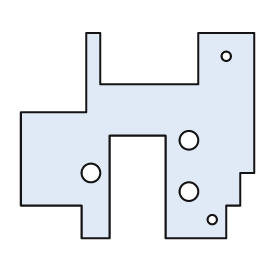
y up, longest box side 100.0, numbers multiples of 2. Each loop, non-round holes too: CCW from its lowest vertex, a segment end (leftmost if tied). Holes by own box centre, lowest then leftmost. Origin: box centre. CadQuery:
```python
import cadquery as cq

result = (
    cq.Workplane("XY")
    .moveTo(-24.0, -44.0)
    .lineTo(-12.0, -44.0)
    .lineTo(-12.0, 0.0)
    .lineTo(12.0, 0.0)
    .lineTo(12.0, -44.0)
    .lineTo(38.0, -44.0)
    .lineTo(38.0, -30.0)
    .lineTo(44.0, -30.0)
    .lineTo(44.0, -16.0)
    .lineTo(50.0, -16.0)
    .lineTo(50.0, 44.0)
    .lineTo(26.0, 44.0)
    .lineTo(26.0, 22.0)
    .lineTo(-16.0, 22.0)
    .lineTo(-16.0, 44.0)
    .lineTo(-22.0, 44.0)
    .lineTo(-22.0, 10.0)
    .lineTo(-50.0, 10.0)
    .lineTo(-50.0, -30.0)
    .lineTo(-24.0, -30.0)
    .close()
    .moveTo(32.0, -36.0)
    .circle(2.0)
    .moveTo(22.0, -24.0)
    .circle(4.0)
    .moveTo(-20.0, -16.0)
    .circle(4.0)
    .moveTo(22.0, -2.0)
    .circle(4.0)
    .moveTo(38.0, 34.0)
    .circle(2.0)
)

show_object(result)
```